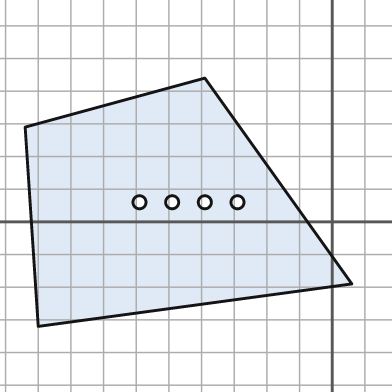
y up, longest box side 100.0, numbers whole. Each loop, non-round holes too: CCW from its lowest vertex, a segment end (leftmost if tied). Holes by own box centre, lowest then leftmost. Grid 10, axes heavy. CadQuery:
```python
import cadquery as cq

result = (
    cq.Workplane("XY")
    .moveTo(-90.0, -32.0)
    .lineTo(6.0, -19.0)
    .lineTo(-39.0, 44.0)
    .lineTo(-94.0, 29.0)
    .close()
    .moveTo(-59.0, 6.0)
    .circle(2.0)
    .moveTo(-49.0, 6.0)
    .circle(2.0)
    .moveTo(-39.0, 6.0)
    .circle(2.0)
    .moveTo(-29.0, 6.0)
    .circle(2.0)
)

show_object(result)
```